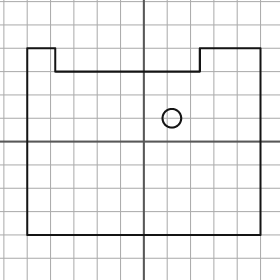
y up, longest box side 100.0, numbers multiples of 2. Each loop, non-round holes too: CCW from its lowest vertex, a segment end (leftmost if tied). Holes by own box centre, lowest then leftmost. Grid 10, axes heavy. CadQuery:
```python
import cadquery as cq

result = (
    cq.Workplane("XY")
    .moveTo(-50.0, -40.0)
    .lineTo(50.0, -40.0)
    .lineTo(50.0, 40.0)
    .lineTo(24.0, 40.0)
    .lineTo(24.0, 30.0)
    .lineTo(-38.0, 30.0)
    .lineTo(-38.0, 40.0)
    .lineTo(-50.0, 40.0)
    .close()
    .moveTo(12.0, 10.0)
    .circle(4.0)
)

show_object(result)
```